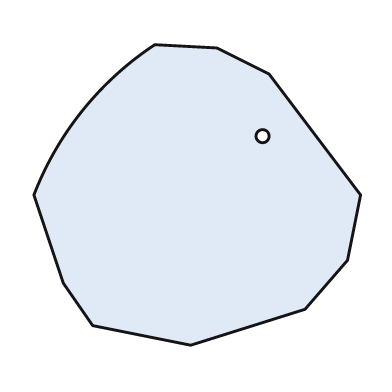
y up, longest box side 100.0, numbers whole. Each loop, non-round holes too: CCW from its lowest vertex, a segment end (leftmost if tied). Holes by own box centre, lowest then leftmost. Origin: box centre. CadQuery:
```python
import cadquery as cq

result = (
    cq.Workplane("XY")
    .moveTo(-2.0, -46.0)
    .lineTo(33.0, -35.0)
    .lineTo(46.0, -20.0)
    .lineTo(50.0, 0.0)
    .lineTo(22.0, 37.0)
    .lineTo(6.0, 45.0)
    .lineTo(-13.0, 46.0)
    .threePointArc((-35.0, 26.0), (-50.0, 0.0))
    .lineTo(-41.0, -27.0)
    .lineTo(-32.0, -40.0)
    .close()
    .moveTo(20.0, 18.0)
    .circle(2.0)
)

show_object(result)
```